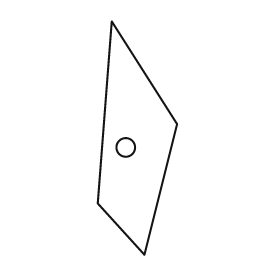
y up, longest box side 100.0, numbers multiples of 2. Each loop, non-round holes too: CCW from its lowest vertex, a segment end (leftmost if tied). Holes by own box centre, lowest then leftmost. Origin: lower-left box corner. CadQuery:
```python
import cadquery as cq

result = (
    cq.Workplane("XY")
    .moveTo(20.0, 0.0)
    .lineTo(34.0, 56.0)
    .lineTo(6.0, 100.0)
    .lineTo(0.0, 22.0)
    .close()
    .moveTo(12.0, 46.0)
    .circle(4.0)
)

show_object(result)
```